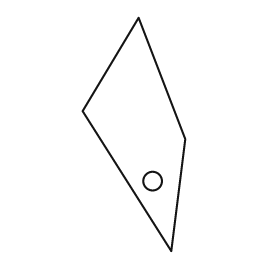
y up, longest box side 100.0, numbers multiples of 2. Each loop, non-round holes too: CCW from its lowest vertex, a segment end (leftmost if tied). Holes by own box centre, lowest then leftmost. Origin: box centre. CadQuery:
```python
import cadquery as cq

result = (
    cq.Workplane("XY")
    .moveTo(16.0, -50.0)
    .lineTo(22.0, -2.0)
    .lineTo(2.0, 50.0)
    .lineTo(-22.0, 10.0)
    .close()
    .moveTo(8.0, -20.0)
    .circle(4.0)
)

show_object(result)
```